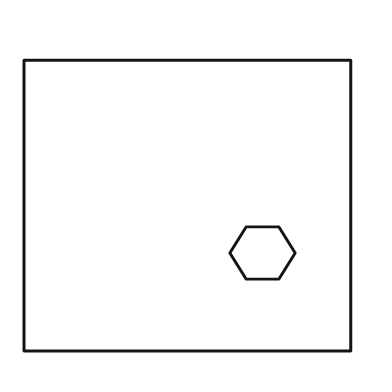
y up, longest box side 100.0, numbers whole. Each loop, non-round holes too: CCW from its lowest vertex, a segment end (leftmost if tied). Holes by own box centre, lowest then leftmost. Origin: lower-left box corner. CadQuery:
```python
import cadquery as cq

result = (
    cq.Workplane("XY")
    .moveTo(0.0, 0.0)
    .lineTo(100.0, 0.0)
    .lineTo(100.0, 89.0)
    .lineTo(0.0, 89.0)
    .close()
    .moveTo(68.0, 22.0)
    .lineTo(78.0, 22.0)
    .lineTo(83.0, 30.0)
    .lineTo(78.0, 38.0)
    .lineTo(68.0, 38.0)
    .lineTo(63.0, 30.0)
    .close()
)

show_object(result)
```